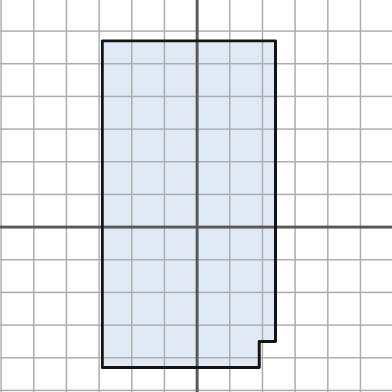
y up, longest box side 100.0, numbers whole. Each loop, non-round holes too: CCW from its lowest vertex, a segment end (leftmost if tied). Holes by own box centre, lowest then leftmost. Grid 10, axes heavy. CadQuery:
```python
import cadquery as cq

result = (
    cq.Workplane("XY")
    .moveTo(-29.0, -43.0)
    .lineTo(19.0, -43.0)
    .lineTo(19.0, -35.0)
    .lineTo(24.0, -35.0)
    .lineTo(24.0, 57.0)
    .lineTo(-29.0, 57.0)
    .close()
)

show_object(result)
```